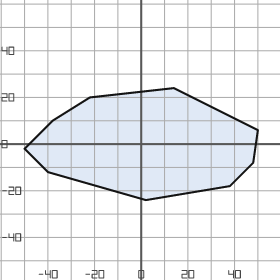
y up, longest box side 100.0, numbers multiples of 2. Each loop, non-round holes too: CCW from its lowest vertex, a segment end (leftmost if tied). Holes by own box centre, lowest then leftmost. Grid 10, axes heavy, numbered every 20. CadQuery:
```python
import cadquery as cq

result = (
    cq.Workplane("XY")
    .moveTo(2.0, -24.0)
    .lineTo(38.0, -18.0)
    .lineTo(48.0, -8.0)
    .lineTo(50.0, 6.0)
    .lineTo(14.0, 24.0)
    .lineTo(-22.0, 20.0)
    .lineTo(-38.0, 10.0)
    .lineTo(-50.0, -2.0)
    .lineTo(-40.0, -12.0)
    .close()
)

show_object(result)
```